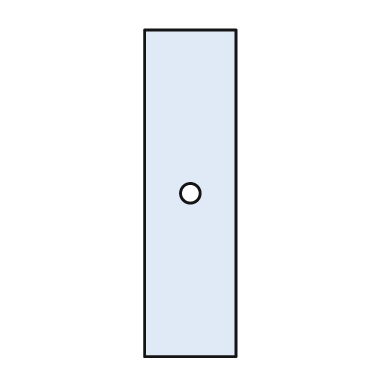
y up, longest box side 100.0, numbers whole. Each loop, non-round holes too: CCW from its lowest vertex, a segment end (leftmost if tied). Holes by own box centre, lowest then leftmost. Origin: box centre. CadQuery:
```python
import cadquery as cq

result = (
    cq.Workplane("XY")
    .moveTo(-14.0, -50.0)
    .lineTo(14.0, -50.0)
    .lineTo(14.0, 50.0)
    .lineTo(-14.0, 50.0)
    .close()
    .moveTo(0.0, 0.0)
    .circle(3.0)
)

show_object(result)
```